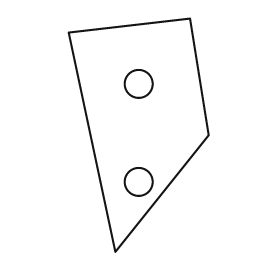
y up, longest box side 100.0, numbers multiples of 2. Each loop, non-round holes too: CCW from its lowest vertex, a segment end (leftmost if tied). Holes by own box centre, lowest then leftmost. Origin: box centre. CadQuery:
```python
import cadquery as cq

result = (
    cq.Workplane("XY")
    .moveTo(-10.0, -50.0)
    .lineTo(30.0, 0.0)
    .lineTo(22.0, 50.0)
    .lineTo(-30.0, 44.0)
    .close()
    .moveTo(0.0, -20.0)
    .circle(6.0)
    .moveTo(0.0, 22.0)
    .circle(6.0)
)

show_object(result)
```